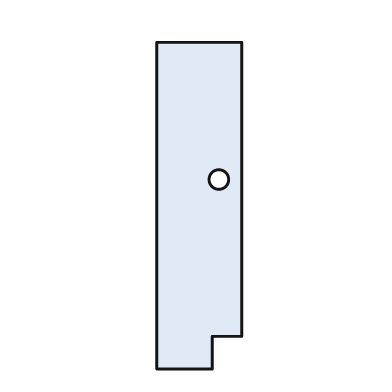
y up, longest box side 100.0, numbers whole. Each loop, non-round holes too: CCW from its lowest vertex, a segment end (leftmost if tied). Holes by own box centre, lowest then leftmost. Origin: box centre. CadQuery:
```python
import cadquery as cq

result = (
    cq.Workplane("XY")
    .moveTo(-13.0, -50.0)
    .lineTo(4.0, -50.0)
    .lineTo(4.0, -40.0)
    .lineTo(13.0, -40.0)
    .lineTo(13.0, 50.0)
    .lineTo(-13.0, 50.0)
    .close()
    .moveTo(6.0, 8.0)
    .circle(3.0)
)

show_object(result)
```